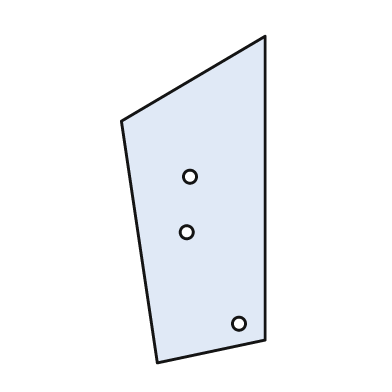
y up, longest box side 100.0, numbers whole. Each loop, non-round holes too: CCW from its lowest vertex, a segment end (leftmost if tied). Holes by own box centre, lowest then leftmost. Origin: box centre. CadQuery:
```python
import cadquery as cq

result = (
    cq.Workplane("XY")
    .moveTo(-11.0, -50.0)
    .lineTo(22.0, -43.0)
    .lineTo(22.0, 50.0)
    .lineTo(-22.0, 24.0)
    .close()
    .moveTo(14.0, -38.0)
    .circle(2.0)
    .moveTo(-2.0, -10.0)
    .circle(2.0)
    .moveTo(-1.0, 7.0)
    .circle(2.0)
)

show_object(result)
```